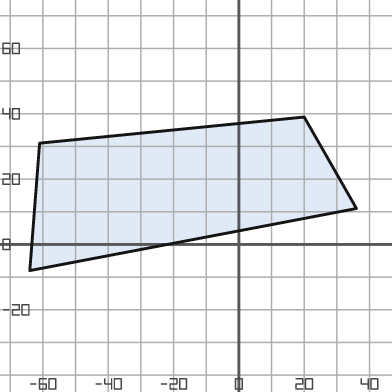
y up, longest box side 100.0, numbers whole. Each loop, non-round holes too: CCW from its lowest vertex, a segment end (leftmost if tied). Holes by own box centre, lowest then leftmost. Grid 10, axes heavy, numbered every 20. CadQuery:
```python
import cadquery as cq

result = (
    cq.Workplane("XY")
    .moveTo(-64.0, -8.0)
    .lineTo(36.0, 11.0)
    .lineTo(20.0, 39.0)
    .lineTo(-61.0, 31.0)
    .close()
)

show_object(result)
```